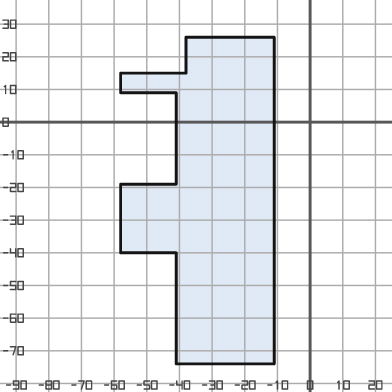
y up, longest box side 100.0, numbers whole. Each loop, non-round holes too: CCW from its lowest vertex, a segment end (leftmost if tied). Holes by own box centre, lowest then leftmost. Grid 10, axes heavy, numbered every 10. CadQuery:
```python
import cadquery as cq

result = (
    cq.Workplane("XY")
    .moveTo(-41.0, -74.0)
    .lineTo(-11.0, -74.0)
    .lineTo(-11.0, 26.0)
    .lineTo(-38.0, 26.0)
    .lineTo(-38.0, 15.0)
    .lineTo(-58.0, 15.0)
    .lineTo(-58.0, 9.0)
    .lineTo(-41.0, 9.0)
    .lineTo(-41.0, -19.0)
    .lineTo(-58.0, -19.0)
    .lineTo(-58.0, -40.0)
    .lineTo(-41.0, -40.0)
    .close()
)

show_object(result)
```